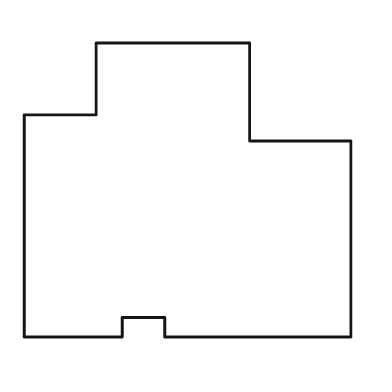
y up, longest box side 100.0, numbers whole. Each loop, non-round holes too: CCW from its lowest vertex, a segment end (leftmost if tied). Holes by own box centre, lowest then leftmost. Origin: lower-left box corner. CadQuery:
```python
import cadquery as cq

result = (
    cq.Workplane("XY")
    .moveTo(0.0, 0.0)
    .lineTo(30.0, 0.0)
    .lineTo(30.0, 6.0)
    .lineTo(43.0, 6.0)
    .lineTo(43.0, 0.0)
    .lineTo(100.0, 0.0)
    .lineTo(100.0, 60.0)
    .lineTo(69.0, 60.0)
    .lineTo(69.0, 90.0)
    .lineTo(22.0, 90.0)
    .lineTo(22.0, 68.0)
    .lineTo(0.0, 68.0)
    .close()
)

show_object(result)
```